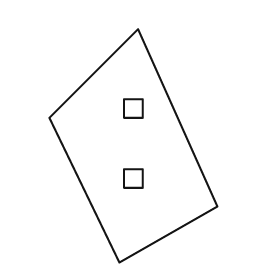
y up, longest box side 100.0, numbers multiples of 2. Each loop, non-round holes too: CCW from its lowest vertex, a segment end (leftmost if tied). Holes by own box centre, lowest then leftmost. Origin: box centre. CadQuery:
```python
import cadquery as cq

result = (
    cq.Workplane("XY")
    .moveTo(-6.0, -50.0)
    .lineTo(36.0, -26.0)
    .lineTo(2.0, 50.0)
    .lineTo(-36.0, 12.0)
    .close()
    .moveTo(-4.0, -18.0)
    .lineTo(4.0, -18.0)
    .lineTo(4.0, -10.0)
    .lineTo(-4.0, -10.0)
    .close()
    .moveTo(-4.0, 12.0)
    .lineTo(4.0, 12.0)
    .lineTo(4.0, 20.0)
    .lineTo(-4.0, 20.0)
    .close()
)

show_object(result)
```